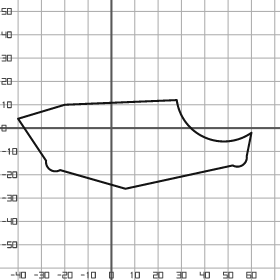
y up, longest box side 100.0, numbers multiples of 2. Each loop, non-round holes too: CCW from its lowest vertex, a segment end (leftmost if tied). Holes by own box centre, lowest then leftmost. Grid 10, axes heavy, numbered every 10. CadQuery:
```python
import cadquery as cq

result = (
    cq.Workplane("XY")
    .moveTo(6.0, -26.0)
    .lineTo(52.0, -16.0)
    .threePointArc((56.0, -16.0), (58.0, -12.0))
    .lineTo(60.0, -2.0)
    .threePointArc((40.0, -4.0), (28.0, 12.0))
    .lineTo(-20.0, 10.0)
    .lineTo(-40.0, 4.0)
    .lineTo(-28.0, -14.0)
    .threePointArc((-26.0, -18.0), (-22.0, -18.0))
    .close()
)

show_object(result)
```